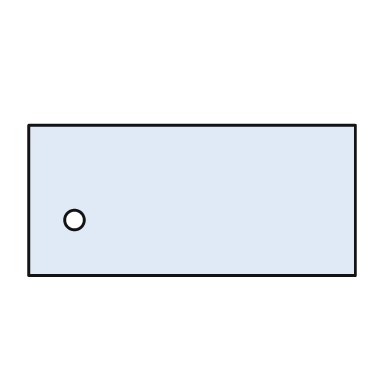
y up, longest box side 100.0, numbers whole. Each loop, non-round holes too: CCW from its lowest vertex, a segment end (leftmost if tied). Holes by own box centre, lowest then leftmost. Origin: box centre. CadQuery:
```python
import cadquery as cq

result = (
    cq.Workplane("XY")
    .moveTo(-50.0, -23.0)
    .lineTo(50.0, -23.0)
    .lineTo(50.0, 23.0)
    .lineTo(-50.0, 23.0)
    .close()
    .moveTo(-36.0, -6.0)
    .circle(3.0)
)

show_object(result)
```